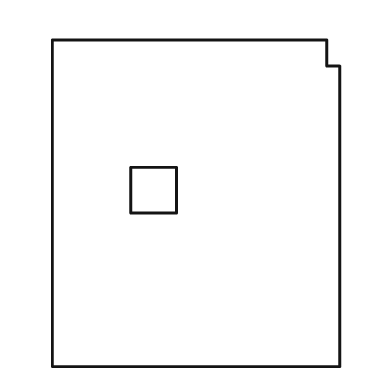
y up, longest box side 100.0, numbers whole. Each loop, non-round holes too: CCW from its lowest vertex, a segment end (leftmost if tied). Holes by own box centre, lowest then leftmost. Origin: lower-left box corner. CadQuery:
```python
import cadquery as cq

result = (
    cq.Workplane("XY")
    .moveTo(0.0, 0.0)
    .lineTo(88.0, 0.0)
    .lineTo(88.0, 92.0)
    .lineTo(84.0, 92.0)
    .lineTo(84.0, 100.0)
    .lineTo(0.0, 100.0)
    .close()
    .moveTo(24.0, 47.0)
    .lineTo(38.0, 47.0)
    .lineTo(38.0, 61.0)
    .lineTo(24.0, 61.0)
    .close()
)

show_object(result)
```